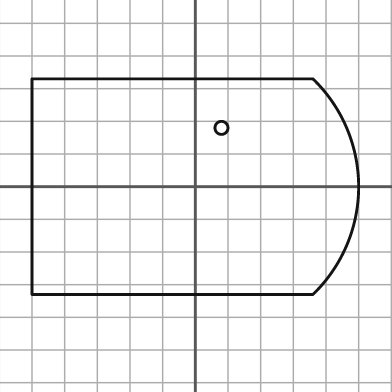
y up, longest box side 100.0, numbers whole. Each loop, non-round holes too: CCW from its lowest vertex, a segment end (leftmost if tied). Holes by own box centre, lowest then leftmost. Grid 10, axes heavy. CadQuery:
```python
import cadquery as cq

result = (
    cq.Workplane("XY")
    .moveTo(-50.0, -33.0)
    .lineTo(36.0, -33.0)
    .threePointArc((50.0, 0.0), (36.0, 33.0))
    .lineTo(-50.0, 33.0)
    .close()
    .moveTo(8.0, 18.0)
    .circle(2.0)
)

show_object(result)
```